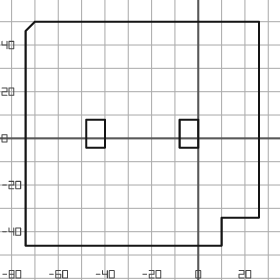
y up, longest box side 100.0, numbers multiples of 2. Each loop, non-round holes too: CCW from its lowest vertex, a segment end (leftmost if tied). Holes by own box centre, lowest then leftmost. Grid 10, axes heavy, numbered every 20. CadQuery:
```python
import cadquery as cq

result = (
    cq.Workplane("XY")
    .moveTo(-74.0, -46.0)
    .lineTo(10.0, -46.0)
    .lineTo(10.0, -34.0)
    .lineTo(26.0, -34.0)
    .lineTo(26.0, 50.0)
    .lineTo(-70.0, 50.0)
    .lineTo(-74.0, 46.0)
    .close()
    .moveTo(-48.0, -4.0)
    .lineTo(-40.0, -4.0)
    .lineTo(-40.0, 8.0)
    .lineTo(-48.0, 8.0)
    .close()
    .moveTo(-8.0, -4.0)
    .lineTo(0.0, -4.0)
    .lineTo(0.0, 8.0)
    .lineTo(-8.0, 8.0)
    .close()
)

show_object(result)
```